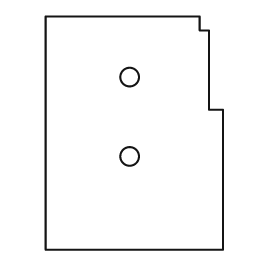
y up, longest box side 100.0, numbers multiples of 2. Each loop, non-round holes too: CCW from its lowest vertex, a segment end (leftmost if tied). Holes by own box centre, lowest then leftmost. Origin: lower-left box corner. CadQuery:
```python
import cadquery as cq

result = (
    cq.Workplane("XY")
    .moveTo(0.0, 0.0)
    .lineTo(76.0, 0.0)
    .lineTo(76.0, 60.0)
    .lineTo(70.0, 60.0)
    .lineTo(70.0, 94.0)
    .lineTo(66.0, 94.0)
    .lineTo(66.0, 100.0)
    .lineTo(0.0, 100.0)
    .close()
    .moveTo(36.0, 40.0)
    .circle(4.0)
    .moveTo(36.0, 74.0)
    .circle(4.0)
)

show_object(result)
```